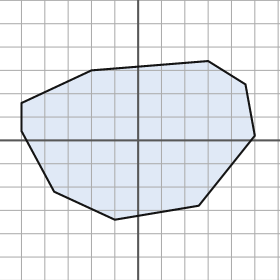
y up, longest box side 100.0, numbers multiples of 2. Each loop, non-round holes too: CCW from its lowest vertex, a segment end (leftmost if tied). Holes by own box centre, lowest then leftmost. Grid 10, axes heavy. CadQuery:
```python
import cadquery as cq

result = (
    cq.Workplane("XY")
    .moveTo(-10.0, -34.0)
    .lineTo(26.0, -28.0)
    .lineTo(50.0, 2.0)
    .lineTo(46.0, 24.0)
    .lineTo(30.0, 34.0)
    .lineTo(-20.0, 30.0)
    .lineTo(-50.0, 16.0)
    .lineTo(-50.0, 4.0)
    .lineTo(-36.0, -22.0)
    .close()
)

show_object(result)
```